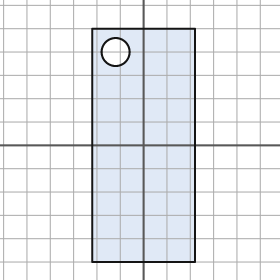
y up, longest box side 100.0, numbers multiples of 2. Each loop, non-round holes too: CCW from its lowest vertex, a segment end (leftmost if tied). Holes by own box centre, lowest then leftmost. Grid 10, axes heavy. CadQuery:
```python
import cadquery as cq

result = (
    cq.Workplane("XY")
    .moveTo(-22.0, -50.0)
    .lineTo(22.0, -50.0)
    .lineTo(22.0, 50.0)
    .lineTo(-22.0, 50.0)
    .close()
    .moveTo(-12.0, 40.0)
    .circle(6.0)
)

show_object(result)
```